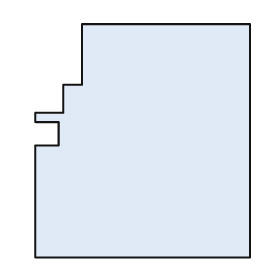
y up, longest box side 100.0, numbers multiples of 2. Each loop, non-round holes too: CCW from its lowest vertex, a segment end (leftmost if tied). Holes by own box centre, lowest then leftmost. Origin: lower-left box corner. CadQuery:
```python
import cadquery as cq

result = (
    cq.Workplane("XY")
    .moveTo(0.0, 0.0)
    .lineTo(92.0, 0.0)
    .lineTo(92.0, 100.0)
    .lineTo(20.0, 100.0)
    .lineTo(20.0, 74.0)
    .lineTo(12.0, 74.0)
    .lineTo(12.0, 62.0)
    .lineTo(0.0, 62.0)
    .lineTo(0.0, 58.0)
    .lineTo(10.0, 58.0)
    .lineTo(10.0, 48.0)
    .lineTo(0.0, 48.0)
    .close()
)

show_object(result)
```